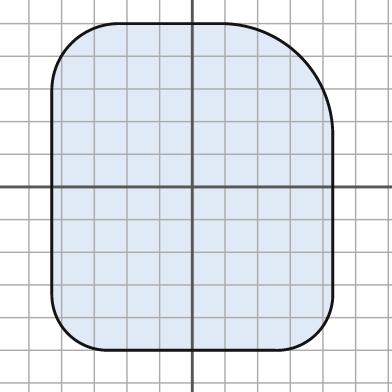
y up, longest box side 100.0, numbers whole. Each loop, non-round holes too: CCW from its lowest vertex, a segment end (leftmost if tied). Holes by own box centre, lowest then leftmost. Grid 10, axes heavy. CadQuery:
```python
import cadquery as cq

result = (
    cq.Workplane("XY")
    .moveTo(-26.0, -50.0)
    .lineTo(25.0, -50.0)
    .threePointArc((38.0, -45.0), (43.0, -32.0))
    .lineTo(43.0, 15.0)
    .threePointArc((33.0, 40.0), (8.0, 50.0))
    .lineTo(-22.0, 50.0)
    .threePointArc((-37.0, 44.0), (-43.0, 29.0))
    .lineTo(-43.0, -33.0)
    .threePointArc((-38.0, -45.0), (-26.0, -50.0))
    .close()
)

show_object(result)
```